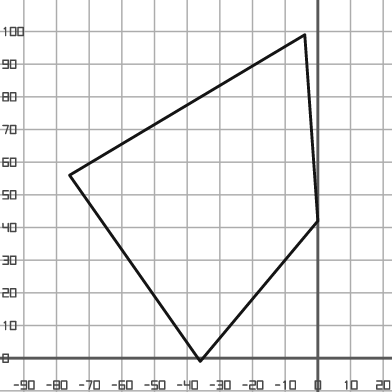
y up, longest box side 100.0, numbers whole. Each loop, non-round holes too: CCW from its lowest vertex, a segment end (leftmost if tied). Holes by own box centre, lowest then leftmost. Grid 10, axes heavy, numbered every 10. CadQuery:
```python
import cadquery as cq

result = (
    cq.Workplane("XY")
    .moveTo(-36.0, -1.0)
    .lineTo(0.0, 42.0)
    .lineTo(-4.0, 99.0)
    .lineTo(-76.0, 56.0)
    .close()
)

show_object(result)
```